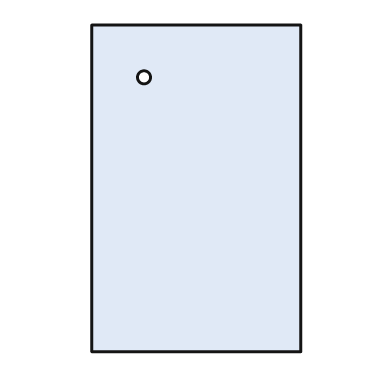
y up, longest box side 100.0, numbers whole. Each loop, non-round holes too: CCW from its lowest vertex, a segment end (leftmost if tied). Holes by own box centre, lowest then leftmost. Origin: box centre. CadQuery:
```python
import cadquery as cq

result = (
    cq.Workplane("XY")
    .moveTo(-32.0, -50.0)
    .lineTo(32.0, -50.0)
    .lineTo(32.0, 50.0)
    .lineTo(-32.0, 50.0)
    .close()
    .moveTo(-16.0, 34.0)
    .circle(2.0)
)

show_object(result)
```